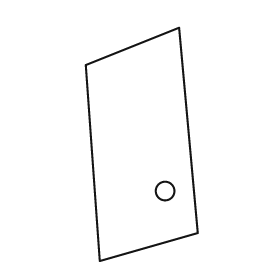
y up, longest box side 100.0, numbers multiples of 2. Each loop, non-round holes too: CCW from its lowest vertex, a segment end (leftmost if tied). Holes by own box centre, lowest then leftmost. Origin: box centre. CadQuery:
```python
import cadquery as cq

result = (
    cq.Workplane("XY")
    .moveTo(-18.0, -50.0)
    .lineTo(24.0, -38.0)
    .lineTo(16.0, 50.0)
    .lineTo(-24.0, 34.0)
    .close()
    .moveTo(10.0, -20.0)
    .circle(4.0)
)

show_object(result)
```